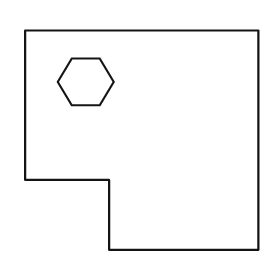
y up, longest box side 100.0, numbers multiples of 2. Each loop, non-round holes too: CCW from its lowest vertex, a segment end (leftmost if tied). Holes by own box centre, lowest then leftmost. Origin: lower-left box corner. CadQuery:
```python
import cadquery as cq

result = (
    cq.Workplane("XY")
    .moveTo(36.0, 0.0)
    .lineTo(100.0, 0.0)
    .lineTo(100.0, 94.0)
    .lineTo(0.0, 94.0)
    .lineTo(0.0, 30.0)
    .lineTo(36.0, 30.0)
    .close()
    .moveTo(20.0, 62.0)
    .lineTo(32.0, 62.0)
    .lineTo(38.0, 72.0)
    .lineTo(32.0, 82.0)
    .lineTo(20.0, 82.0)
    .lineTo(14.0, 72.0)
    .close()
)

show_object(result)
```